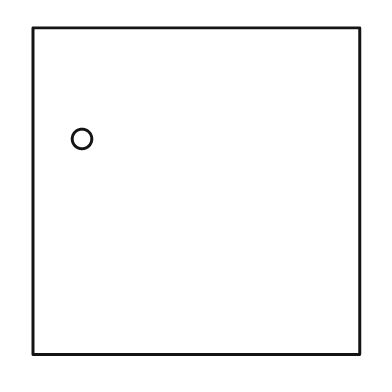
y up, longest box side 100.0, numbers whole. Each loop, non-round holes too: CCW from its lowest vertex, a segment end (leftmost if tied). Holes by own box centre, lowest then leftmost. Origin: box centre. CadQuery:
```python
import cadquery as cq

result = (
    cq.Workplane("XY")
    .moveTo(-50.0, -50.0)
    .lineTo(50.0, -50.0)
    .lineTo(50.0, 50.0)
    .lineTo(-50.0, 50.0)
    .close()
    .moveTo(-35.0, 16.0)
    .circle(3.0)
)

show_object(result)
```